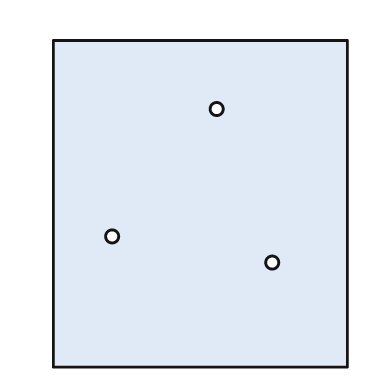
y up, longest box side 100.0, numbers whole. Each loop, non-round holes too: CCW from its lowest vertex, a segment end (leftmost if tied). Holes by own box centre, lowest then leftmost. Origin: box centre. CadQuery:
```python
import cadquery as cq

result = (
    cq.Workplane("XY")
    .moveTo(-45.0, -50.0)
    .lineTo(45.0, -50.0)
    .lineTo(45.0, 50.0)
    .lineTo(-45.0, 50.0)
    .close()
    .moveTo(22.0, -18.0)
    .circle(2.0)
    .moveTo(-27.0, -10.0)
    .circle(2.0)
    .moveTo(5.0, 29.0)
    .circle(2.0)
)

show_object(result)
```